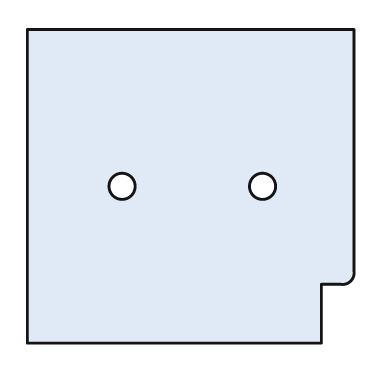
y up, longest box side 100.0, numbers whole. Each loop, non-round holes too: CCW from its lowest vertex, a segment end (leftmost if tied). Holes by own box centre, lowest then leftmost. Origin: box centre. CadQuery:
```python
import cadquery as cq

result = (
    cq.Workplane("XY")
    .moveTo(-50.0, -48.0)
    .lineTo(40.0, -48.0)
    .lineTo(40.0, -30.0)
    .lineTo(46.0, -30.0)
    .threePointArc((49.0, -29.0), (50.0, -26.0))
    .lineTo(50.0, 48.0)
    .lineTo(-50.0, 48.0)
    .close()
    .moveTo(-21.0, 0.0)
    .circle(4.0)
    .moveTo(22.0, 0.0)
    .circle(4.0)
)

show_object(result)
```